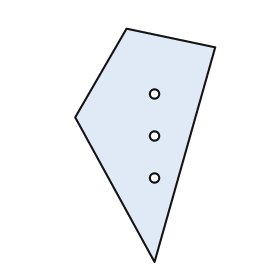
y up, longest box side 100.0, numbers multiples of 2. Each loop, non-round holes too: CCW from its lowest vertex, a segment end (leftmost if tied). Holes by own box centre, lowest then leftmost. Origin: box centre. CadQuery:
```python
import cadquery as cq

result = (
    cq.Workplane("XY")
    .moveTo(4.0, -50.0)
    .lineTo(30.0, 42.0)
    .lineTo(-8.0, 50.0)
    .lineTo(-30.0, 12.0)
    .close()
    .moveTo(4.0, -14.0)
    .circle(2.0)
    .moveTo(4.0, 4.0)
    .circle(2.0)
    .moveTo(4.0, 22.0)
    .circle(2.0)
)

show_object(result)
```